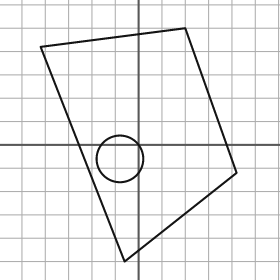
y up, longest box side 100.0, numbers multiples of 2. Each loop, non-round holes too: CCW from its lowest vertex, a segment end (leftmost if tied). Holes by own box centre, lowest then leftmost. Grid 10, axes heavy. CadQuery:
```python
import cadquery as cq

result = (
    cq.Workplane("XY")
    .moveTo(-6.0, -50.0)
    .lineTo(42.0, -12.0)
    .lineTo(20.0, 50.0)
    .lineTo(-42.0, 42.0)
    .close()
    .moveTo(-8.0, -6.0)
    .circle(10.0)
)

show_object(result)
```